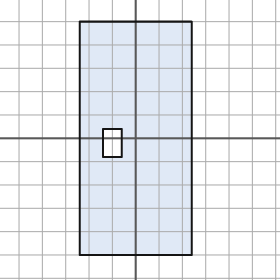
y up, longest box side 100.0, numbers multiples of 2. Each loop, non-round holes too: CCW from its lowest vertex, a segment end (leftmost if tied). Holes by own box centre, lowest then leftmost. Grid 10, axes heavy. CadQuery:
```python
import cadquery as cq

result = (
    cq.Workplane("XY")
    .moveTo(-24.0, -50.0)
    .lineTo(24.0, -50.0)
    .lineTo(24.0, 50.0)
    .lineTo(-24.0, 50.0)
    .close()
    .moveTo(-14.0, -8.0)
    .lineTo(-6.0, -8.0)
    .lineTo(-6.0, 4.0)
    .lineTo(-14.0, 4.0)
    .close()
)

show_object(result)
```